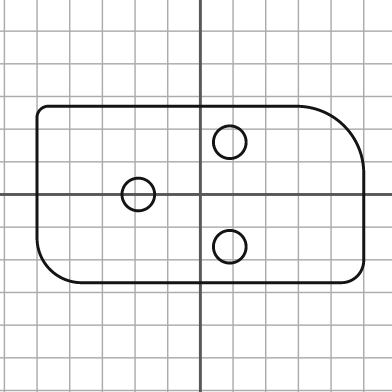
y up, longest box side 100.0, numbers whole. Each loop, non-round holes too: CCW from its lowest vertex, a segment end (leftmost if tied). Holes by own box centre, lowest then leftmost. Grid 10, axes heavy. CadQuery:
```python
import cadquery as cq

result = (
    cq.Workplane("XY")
    .moveTo(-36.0, -27.0)
    .lineTo(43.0, -27.0)
    .threePointArc((48.0, -25.0), (50.0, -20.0))
    .lineTo(50.0, 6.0)
    .threePointArc((44.0, 21.0), (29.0, 27.0))
    .lineTo(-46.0, 27.0)
    .threePointArc((-49.0, 26.0), (-50.0, 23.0))
    .lineTo(-50.0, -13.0)
    .threePointArc((-46.0, -23.0), (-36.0, -27.0))
    .close()
    .moveTo(9.0, -16.0)
    .circle(5.0)
    .moveTo(-19.0, 0.0)
    .circle(5.0)
    .moveTo(9.0, 16.0)
    .circle(5.0)
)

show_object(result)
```